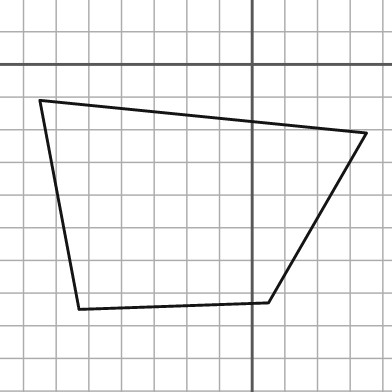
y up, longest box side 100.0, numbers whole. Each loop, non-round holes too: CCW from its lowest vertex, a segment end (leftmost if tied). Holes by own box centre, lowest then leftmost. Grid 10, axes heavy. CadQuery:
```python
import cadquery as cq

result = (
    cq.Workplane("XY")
    .moveTo(-53.0, -75.0)
    .lineTo(5.0, -73.0)
    .lineTo(35.0, -21.0)
    .lineTo(-65.0, -11.0)
    .close()
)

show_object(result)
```